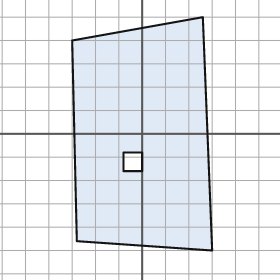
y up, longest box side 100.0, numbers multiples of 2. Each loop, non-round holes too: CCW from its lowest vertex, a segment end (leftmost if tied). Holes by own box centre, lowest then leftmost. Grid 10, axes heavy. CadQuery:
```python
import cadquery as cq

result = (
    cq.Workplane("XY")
    .moveTo(30.0, -50.0)
    .lineTo(26.0, 50.0)
    .lineTo(-30.0, 40.0)
    .lineTo(-28.0, -46.0)
    .close()
    .moveTo(-8.0, -16.0)
    .lineTo(0.0, -16.0)
    .lineTo(0.0, -8.0)
    .lineTo(-8.0, -8.0)
    .close()
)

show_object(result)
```